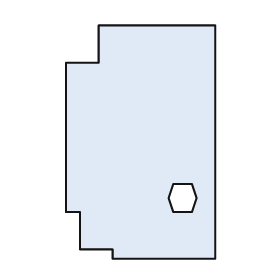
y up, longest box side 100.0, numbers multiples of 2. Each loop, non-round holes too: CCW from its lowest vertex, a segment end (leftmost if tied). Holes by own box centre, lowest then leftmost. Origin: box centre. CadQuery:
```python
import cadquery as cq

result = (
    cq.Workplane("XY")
    .moveTo(-12.0, -50.0)
    .lineTo(32.0, -50.0)
    .lineTo(32.0, 50.0)
    .lineTo(-18.0, 50.0)
    .lineTo(-18.0, 34.0)
    .lineTo(-32.0, 34.0)
    .lineTo(-32.0, -30.0)
    .lineTo(-26.0, -30.0)
    .lineTo(-26.0, -46.0)
    .lineTo(-12.0, -46.0)
    .close()
    .moveTo(14.0, -30.0)
    .lineTo(22.0, -30.0)
    .lineTo(24.0, -24.0)
    .lineTo(22.0, -18.0)
    .lineTo(14.0, -18.0)
    .lineTo(12.0, -24.0)
    .close()
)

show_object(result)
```